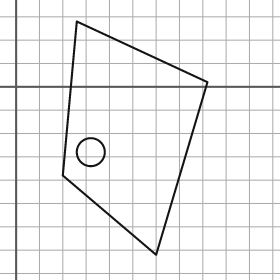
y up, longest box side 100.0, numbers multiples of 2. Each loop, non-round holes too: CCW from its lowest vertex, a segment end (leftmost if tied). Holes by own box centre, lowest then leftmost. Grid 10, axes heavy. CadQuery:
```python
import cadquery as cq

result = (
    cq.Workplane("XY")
    .moveTo(60.0, -72.0)
    .lineTo(82.0, 2.0)
    .lineTo(26.0, 28.0)
    .lineTo(20.0, -38.0)
    .close()
    .moveTo(32.0, -28.0)
    .circle(6.0)
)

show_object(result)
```